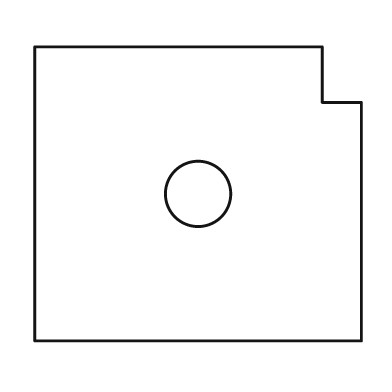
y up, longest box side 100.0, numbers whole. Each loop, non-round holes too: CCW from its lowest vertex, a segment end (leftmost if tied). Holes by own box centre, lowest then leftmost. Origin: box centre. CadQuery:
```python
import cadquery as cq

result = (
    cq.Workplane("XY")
    .moveTo(-50.0, -45.0)
    .lineTo(50.0, -45.0)
    .lineTo(50.0, 28.0)
    .lineTo(38.0, 28.0)
    .lineTo(38.0, 45.0)
    .lineTo(-50.0, 45.0)
    .close()
    .moveTo(0.0, 0.0)
    .circle(10.0)
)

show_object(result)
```